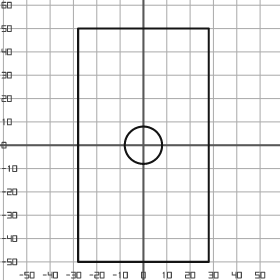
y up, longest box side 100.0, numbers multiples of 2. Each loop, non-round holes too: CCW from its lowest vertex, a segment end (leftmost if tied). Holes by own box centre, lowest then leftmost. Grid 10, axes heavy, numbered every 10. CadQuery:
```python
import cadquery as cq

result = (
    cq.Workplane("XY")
    .moveTo(-28.0, -50.0)
    .lineTo(28.0, -50.0)
    .lineTo(28.0, 50.0)
    .lineTo(-28.0, 50.0)
    .close()
    .moveTo(0.0, 0.0)
    .circle(8.0)
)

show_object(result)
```